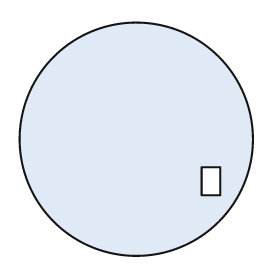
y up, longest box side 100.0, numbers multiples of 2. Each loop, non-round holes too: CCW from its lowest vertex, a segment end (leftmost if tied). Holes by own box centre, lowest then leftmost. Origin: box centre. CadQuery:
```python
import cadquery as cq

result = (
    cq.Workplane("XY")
    .moveTo(0.0, 0.0)
    .circle(50.0)
    .moveTo(28.0, -24.0)
    .lineTo(36.0, -24.0)
    .lineTo(36.0, -12.0)
    .lineTo(28.0, -12.0)
    .close()
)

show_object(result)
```